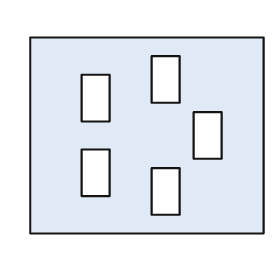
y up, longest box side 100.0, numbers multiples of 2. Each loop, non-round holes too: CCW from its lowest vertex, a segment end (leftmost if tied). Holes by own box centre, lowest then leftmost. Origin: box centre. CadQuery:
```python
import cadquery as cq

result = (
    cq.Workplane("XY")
    .moveTo(-50.0, -42.0)
    .lineTo(50.0, -42.0)
    .lineTo(50.0, 42.0)
    .lineTo(-50.0, 42.0)
    .close()
    .moveTo(2.0, -34.0)
    .lineTo(14.0, -34.0)
    .lineTo(14.0, -14.0)
    .lineTo(2.0, -14.0)
    .close()
    .moveTo(-28.0, -26.0)
    .lineTo(-16.0, -26.0)
    .lineTo(-16.0, -6.0)
    .lineTo(-28.0, -6.0)
    .close()
    .moveTo(20.0, -10.0)
    .lineTo(32.0, -10.0)
    .lineTo(32.0, 10.0)
    .lineTo(20.0, 10.0)
    .close()
    .moveTo(-28.0, 6.0)
    .lineTo(-16.0, 6.0)
    .lineTo(-16.0, 26.0)
    .lineTo(-28.0, 26.0)
    .close()
    .moveTo(2.0, 14.0)
    .lineTo(14.0, 14.0)
    .lineTo(14.0, 34.0)
    .lineTo(2.0, 34.0)
    .close()
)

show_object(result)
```